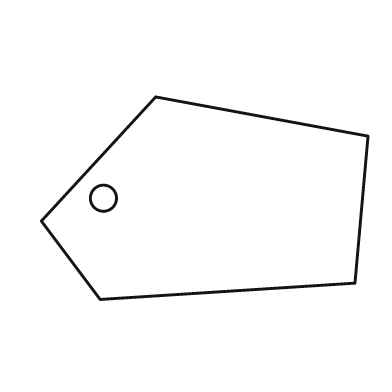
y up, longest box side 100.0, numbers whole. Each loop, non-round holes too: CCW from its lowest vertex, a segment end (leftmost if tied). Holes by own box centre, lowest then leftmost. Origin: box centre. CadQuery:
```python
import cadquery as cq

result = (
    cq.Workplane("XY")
    .moveTo(-32.0, -31.0)
    .lineTo(46.0, -26.0)
    .lineTo(50.0, 19.0)
    .lineTo(-15.0, 31.0)
    .lineTo(-50.0, -7.0)
    .close()
    .moveTo(-31.0, 0.0)
    .circle(4.0)
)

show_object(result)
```